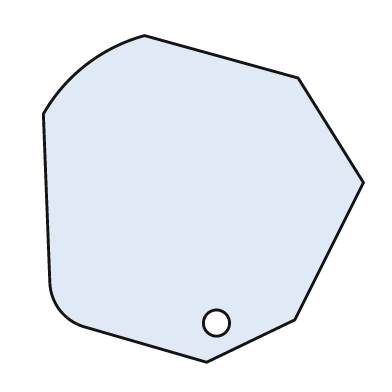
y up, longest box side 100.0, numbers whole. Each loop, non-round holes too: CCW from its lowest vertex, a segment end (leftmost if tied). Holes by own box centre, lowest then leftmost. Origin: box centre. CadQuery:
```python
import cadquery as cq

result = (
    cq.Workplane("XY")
    .moveTo(1.0, -50.0)
    .lineTo(28.0, -37.0)
    .lineTo(49.0, 5.0)
    .lineTo(29.0, 37.0)
    .lineTo(-18.0, 50.0)
    .threePointArc((-36.0, 41.0), (-49.0, 26.0))
    .lineTo(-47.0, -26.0)
    .threePointArc((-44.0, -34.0), (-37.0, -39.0))
    .close()
    .moveTo(4.0, -38.0)
    .circle(4.0)
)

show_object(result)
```